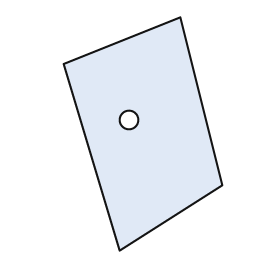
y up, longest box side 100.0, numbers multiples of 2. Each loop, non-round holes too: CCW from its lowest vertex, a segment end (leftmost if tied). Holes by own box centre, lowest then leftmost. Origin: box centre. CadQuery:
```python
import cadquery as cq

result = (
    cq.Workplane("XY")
    .moveTo(-10.0, -50.0)
    .lineTo(34.0, -22.0)
    .lineTo(16.0, 50.0)
    .lineTo(-34.0, 30.0)
    .close()
    .moveTo(-6.0, 6.0)
    .circle(4.0)
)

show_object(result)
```